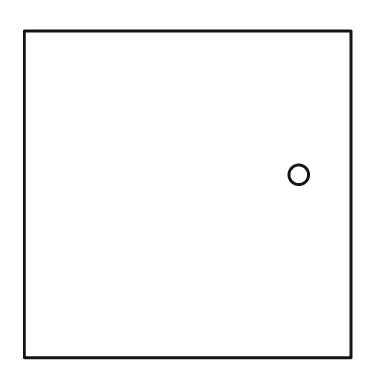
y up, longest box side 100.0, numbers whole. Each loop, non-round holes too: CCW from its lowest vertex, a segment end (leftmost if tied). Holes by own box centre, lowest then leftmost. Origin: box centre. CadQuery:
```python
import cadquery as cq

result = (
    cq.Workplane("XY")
    .moveTo(-50.0, -50.0)
    .lineTo(50.0, -50.0)
    .lineTo(50.0, 50.0)
    .lineTo(-50.0, 50.0)
    .close()
    .moveTo(34.0, 6.0)
    .circle(3.0)
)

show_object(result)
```